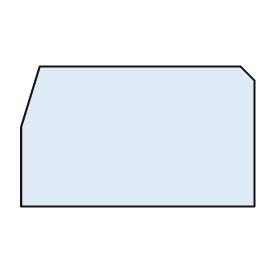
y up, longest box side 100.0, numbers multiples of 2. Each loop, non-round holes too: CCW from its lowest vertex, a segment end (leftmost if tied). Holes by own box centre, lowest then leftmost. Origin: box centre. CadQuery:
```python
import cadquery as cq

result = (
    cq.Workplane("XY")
    .moveTo(-50.0, -30.0)
    .lineTo(50.0, -30.0)
    .lineTo(50.0, 24.0)
    .lineTo(44.0, 30.0)
    .lineTo(-42.0, 30.0)
    .lineTo(-50.0, 4.0)
    .close()
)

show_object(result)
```